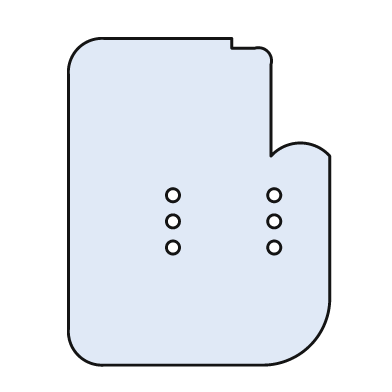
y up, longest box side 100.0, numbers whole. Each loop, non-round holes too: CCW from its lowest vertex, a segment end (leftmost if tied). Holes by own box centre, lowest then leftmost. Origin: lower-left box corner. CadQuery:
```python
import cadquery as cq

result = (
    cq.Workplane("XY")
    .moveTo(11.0, 0.0)
    .lineTo(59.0, 0.0)
    .threePointArc((74.0, 6.0), (80.0, 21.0))
    .lineTo(80.0, 64.0)
    .threePointArc((71.0, 68.0), (62.0, 64.0))
    .lineTo(62.0, 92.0)
    .threePointArc((61.0, 96.0), (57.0, 97.0))
    .lineTo(50.0, 97.0)
    .lineTo(50.0, 100.0)
    .lineTo(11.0, 100.0)
    .threePointArc((3.0, 97.0), (0.0, 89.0))
    .lineTo(0.0, 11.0)
    .threePointArc((3.0, 3.0), (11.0, 0.0))
    .close()
    .moveTo(32.0, 36.0)
    .circle(2.0)
    .moveTo(63.0, 36.0)
    .circle(2.0)
    .moveTo(32.0, 44.0)
    .circle(2.0)
    .moveTo(63.0, 44.0)
    .circle(2.0)
    .moveTo(32.0, 52.0)
    .circle(2.0)
    .moveTo(63.0, 52.0)
    .circle(2.0)
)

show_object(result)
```